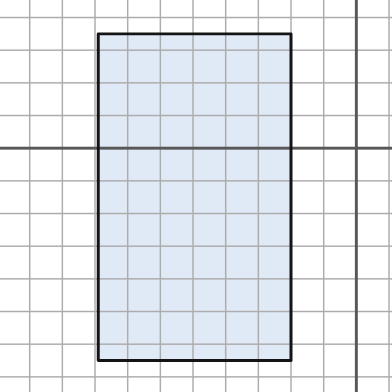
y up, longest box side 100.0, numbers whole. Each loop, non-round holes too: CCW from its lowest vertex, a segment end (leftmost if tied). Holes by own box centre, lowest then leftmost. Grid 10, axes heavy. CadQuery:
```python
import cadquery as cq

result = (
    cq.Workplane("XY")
    .moveTo(-79.0, -65.0)
    .lineTo(-20.0, -65.0)
    .lineTo(-20.0, 35.0)
    .lineTo(-79.0, 35.0)
    .close()
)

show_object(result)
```